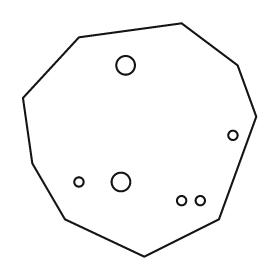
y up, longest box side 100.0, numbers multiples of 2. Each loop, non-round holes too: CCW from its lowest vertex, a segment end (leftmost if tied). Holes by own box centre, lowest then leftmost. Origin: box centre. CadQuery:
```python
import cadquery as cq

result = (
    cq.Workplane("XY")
    .moveTo(2.0, -50.0)
    .lineTo(34.0, -34.0)
    .lineTo(50.0, 10.0)
    .lineTo(42.0, 32.0)
    .lineTo(18.0, 50.0)
    .lineTo(-26.0, 44.0)
    .lineTo(-50.0, 18.0)
    .lineTo(-46.0, -10.0)
    .lineTo(-32.0, -34.0)
    .close()
    .moveTo(18.0, -26.0)
    .circle(2.0)
    .moveTo(26.0, -26.0)
    .circle(2.0)
    .moveTo(-26.0, -18.0)
    .circle(2.0)
    .moveTo(-8.0, -18.0)
    .circle(4.0)
    .moveTo(40.0, 2.0)
    .circle(2.0)
    .moveTo(-6.0, 32.0)
    .circle(4.0)
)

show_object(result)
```